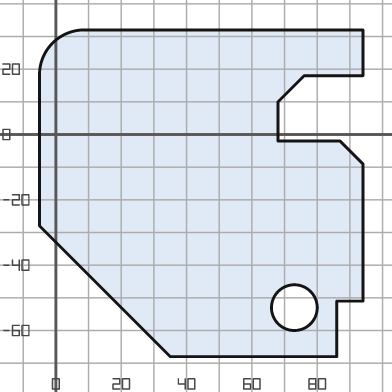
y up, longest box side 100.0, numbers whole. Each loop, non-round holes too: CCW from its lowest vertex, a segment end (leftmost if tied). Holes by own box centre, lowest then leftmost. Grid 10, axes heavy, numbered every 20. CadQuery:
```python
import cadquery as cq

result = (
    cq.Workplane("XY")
    .moveTo(35.0, -68.0)
    .lineTo(86.0, -68.0)
    .lineTo(86.0, -51.0)
    .lineTo(94.0, -51.0)
    .lineTo(94.0, -9.0)
    .lineTo(87.0, -2.0)
    .lineTo(68.0, -2.0)
    .lineTo(68.0, 10.0)
    .lineTo(76.0, 18.0)
    .lineTo(94.0, 18.0)
    .lineTo(94.0, 32.0)
    .lineTo(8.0, 32.0)
    .threePointArc((-1.0, 28.0), (-5.0, 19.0))
    .lineTo(-5.0, -28.0)
    .close()
    .moveTo(73.0, -53.0)
    .circle(7.0)
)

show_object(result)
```